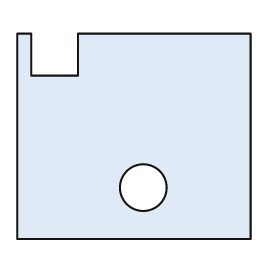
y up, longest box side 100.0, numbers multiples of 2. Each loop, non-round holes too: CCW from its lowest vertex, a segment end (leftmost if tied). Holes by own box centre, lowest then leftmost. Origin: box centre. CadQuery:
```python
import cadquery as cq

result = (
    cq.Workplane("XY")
    .moveTo(-50.0, -44.0)
    .lineTo(50.0, -44.0)
    .lineTo(50.0, 44.0)
    .lineTo(-24.0, 44.0)
    .lineTo(-24.0, 26.0)
    .lineTo(-44.0, 26.0)
    .lineTo(-44.0, 44.0)
    .lineTo(-50.0, 44.0)
    .close()
    .moveTo(4.0, -22.0)
    .circle(10.0)
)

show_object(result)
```